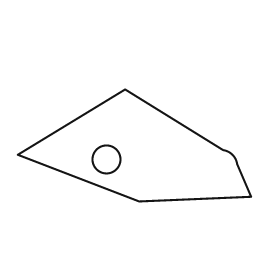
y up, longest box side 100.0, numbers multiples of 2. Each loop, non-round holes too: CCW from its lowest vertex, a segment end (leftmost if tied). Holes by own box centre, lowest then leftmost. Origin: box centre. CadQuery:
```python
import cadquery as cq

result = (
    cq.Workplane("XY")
    .moveTo(2.0, -24.0)
    .lineTo(50.0, -22.0)
    .lineTo(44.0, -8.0)
    .threePointArc((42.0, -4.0), (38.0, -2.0))
    .lineTo(-4.0, 24.0)
    .lineTo(-50.0, -4.0)
    .close()
    .moveTo(-12.0, -6.0)
    .circle(6.0)
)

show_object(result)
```